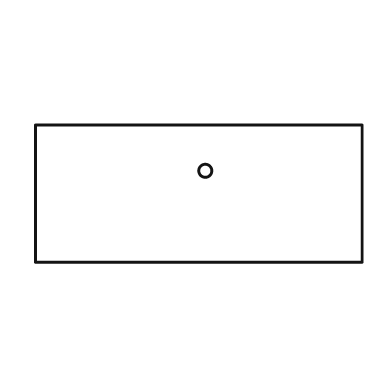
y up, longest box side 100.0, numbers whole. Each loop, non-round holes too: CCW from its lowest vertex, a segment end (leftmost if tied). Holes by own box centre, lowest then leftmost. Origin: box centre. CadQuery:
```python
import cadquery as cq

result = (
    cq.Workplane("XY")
    .moveTo(-50.0, -21.0)
    .lineTo(50.0, -21.0)
    .lineTo(50.0, 21.0)
    .lineTo(-50.0, 21.0)
    .close()
    .moveTo(2.0, 7.0)
    .circle(2.0)
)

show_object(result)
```